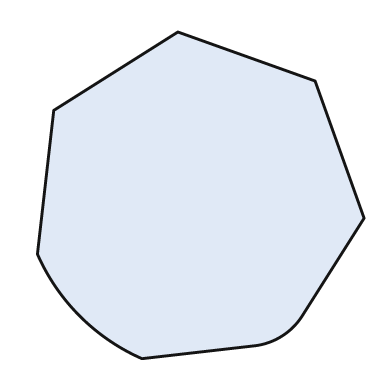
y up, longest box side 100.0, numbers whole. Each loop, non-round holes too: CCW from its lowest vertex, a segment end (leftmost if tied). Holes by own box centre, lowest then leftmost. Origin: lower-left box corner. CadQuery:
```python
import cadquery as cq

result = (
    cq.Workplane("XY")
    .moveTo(32.0, 0.0)
    .lineTo(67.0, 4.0)
    .threePointArc((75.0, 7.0), (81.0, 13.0))
    .lineTo(100.0, 43.0)
    .lineTo(85.0, 85.0)
    .lineTo(43.0, 100.0)
    .lineTo(5.0, 76.0)
    .lineTo(0.0, 32.0)
    .threePointArc((13.0, 13.0), (32.0, 0.0))
    .close()
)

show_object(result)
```